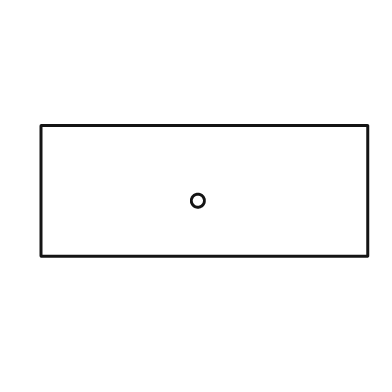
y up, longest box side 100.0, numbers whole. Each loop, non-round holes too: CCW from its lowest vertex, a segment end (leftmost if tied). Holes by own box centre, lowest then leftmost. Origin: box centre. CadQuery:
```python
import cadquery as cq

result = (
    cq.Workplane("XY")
    .moveTo(-50.0, -20.0)
    .lineTo(50.0, -20.0)
    .lineTo(50.0, 20.0)
    .lineTo(-50.0, 20.0)
    .close()
    .moveTo(-2.0, -3.0)
    .circle(2.0)
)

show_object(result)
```